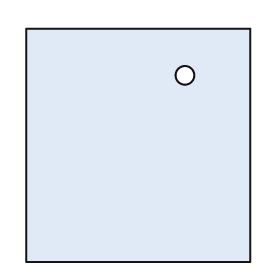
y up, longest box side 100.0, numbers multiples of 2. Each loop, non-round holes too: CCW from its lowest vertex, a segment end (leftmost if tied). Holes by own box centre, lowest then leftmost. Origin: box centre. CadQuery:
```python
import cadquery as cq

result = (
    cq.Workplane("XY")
    .moveTo(-48.0, -50.0)
    .lineTo(48.0, -50.0)
    .lineTo(48.0, 50.0)
    .lineTo(-48.0, 50.0)
    .close()
    .moveTo(20.0, 30.0)
    .circle(4.0)
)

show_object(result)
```